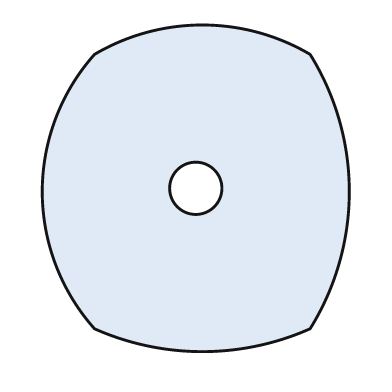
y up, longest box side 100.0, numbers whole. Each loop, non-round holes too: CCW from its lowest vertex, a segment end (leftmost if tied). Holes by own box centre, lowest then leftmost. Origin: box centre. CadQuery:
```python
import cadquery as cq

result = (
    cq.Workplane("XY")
    .moveTo(-31.0, -43.0)
    .threePointArc((2.0, -50.0), (35.0, -43.0))
    .threePointArc((47.0, -1.0), (35.0, 41.0))
    .threePointArc((2.0, 50.0), (-31.0, 41.0))
    .threePointArc((-47.0, -1.0), (-31.0, -43.0))
    .close()
    .moveTo(0.0, 0.0)
    .circle(8.0)
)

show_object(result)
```